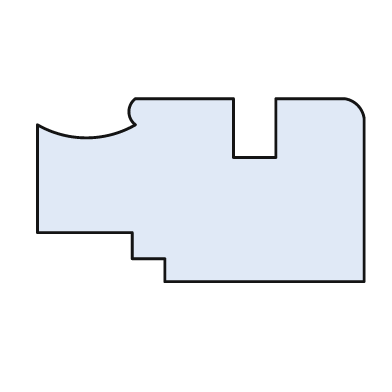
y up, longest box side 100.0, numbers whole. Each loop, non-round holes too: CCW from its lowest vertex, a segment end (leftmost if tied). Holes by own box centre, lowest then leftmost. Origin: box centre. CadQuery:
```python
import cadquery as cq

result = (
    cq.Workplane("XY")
    .moveTo(-11.0, -28.0)
    .lineTo(50.0, -28.0)
    .lineTo(50.0, 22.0)
    .threePointArc((48.0, 26.0), (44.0, 28.0))
    .lineTo(23.0, 28.0)
    .lineTo(23.0, 10.0)
    .lineTo(10.0, 10.0)
    .lineTo(10.0, 28.0)
    .lineTo(-20.0, 28.0)
    .threePointArc((-22.0, 24.0), (-20.0, 20.0))
    .threePointArc((-35.0, 16.0), (-50.0, 20.0))
    .lineTo(-50.0, -13.0)
    .lineTo(-21.0, -13.0)
    .lineTo(-21.0, -21.0)
    .lineTo(-11.0, -21.0)
    .close()
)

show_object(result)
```